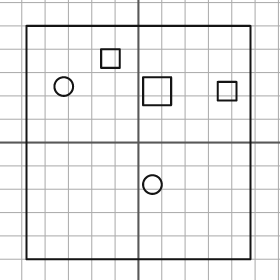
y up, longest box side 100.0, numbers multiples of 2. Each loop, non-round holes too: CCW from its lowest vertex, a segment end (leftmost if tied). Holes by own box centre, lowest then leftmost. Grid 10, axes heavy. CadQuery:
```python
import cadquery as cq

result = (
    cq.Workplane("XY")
    .moveTo(-48.0, -50.0)
    .lineTo(48.0, -50.0)
    .lineTo(48.0, 50.0)
    .lineTo(-48.0, 50.0)
    .close()
    .moveTo(6.0, -18.0)
    .circle(4.0)
    .moveTo(2.0, 16.0)
    .lineTo(14.0, 16.0)
    .lineTo(14.0, 28.0)
    .lineTo(2.0, 28.0)
    .close()
    .moveTo(34.0, 18.0)
    .lineTo(42.0, 18.0)
    .lineTo(42.0, 26.0)
    .lineTo(34.0, 26.0)
    .close()
    .moveTo(-32.0, 24.0)
    .circle(4.0)
    .moveTo(-16.0, 32.0)
    .lineTo(-8.0, 32.0)
    .lineTo(-8.0, 40.0)
    .lineTo(-16.0, 40.0)
    .close()
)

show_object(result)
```